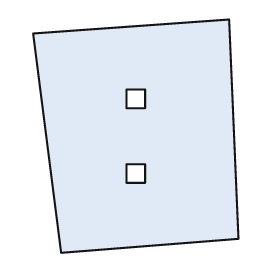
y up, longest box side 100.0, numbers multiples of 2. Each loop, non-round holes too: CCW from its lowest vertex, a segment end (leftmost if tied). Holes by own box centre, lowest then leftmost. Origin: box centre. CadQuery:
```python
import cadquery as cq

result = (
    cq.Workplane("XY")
    .moveTo(-32.0, -50.0)
    .lineTo(44.0, -44.0)
    .lineTo(40.0, 50.0)
    .lineTo(-44.0, 44.0)
    .close()
    .moveTo(-4.0, -20.0)
    .lineTo(4.0, -20.0)
    .lineTo(4.0, -12.0)
    .lineTo(-4.0, -12.0)
    .close()
    .moveTo(-4.0, 12.0)
    .lineTo(4.0, 12.0)
    .lineTo(4.0, 20.0)
    .lineTo(-4.0, 20.0)
    .close()
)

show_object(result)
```